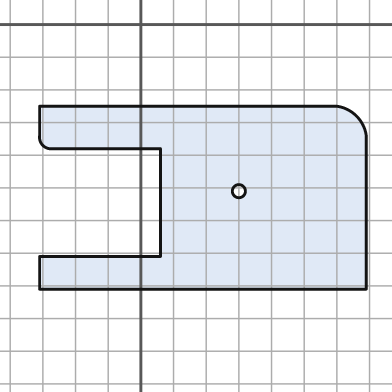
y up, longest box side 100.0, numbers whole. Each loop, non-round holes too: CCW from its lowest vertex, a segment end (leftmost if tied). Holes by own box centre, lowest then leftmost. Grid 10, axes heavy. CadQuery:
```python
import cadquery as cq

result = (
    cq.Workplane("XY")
    .moveTo(-31.0, -81.0)
    .lineTo(69.0, -81.0)
    .lineTo(69.0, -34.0)
    .threePointArc((66.0, -28.0), (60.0, -25.0))
    .lineTo(-31.0, -25.0)
    .lineTo(-31.0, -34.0)
    .threePointArc((-30.0, -37.0), (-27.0, -38.0))
    .lineTo(6.0, -38.0)
    .lineTo(6.0, -71.0)
    .lineTo(-31.0, -71.0)
    .close()
    .moveTo(30.0, -51.0)
    .circle(2.0)
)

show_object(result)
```